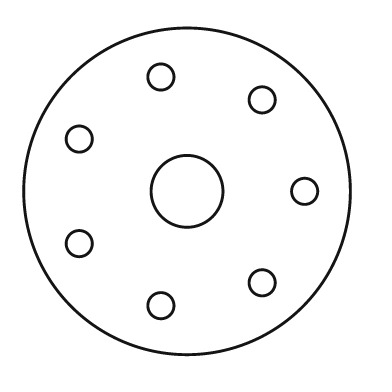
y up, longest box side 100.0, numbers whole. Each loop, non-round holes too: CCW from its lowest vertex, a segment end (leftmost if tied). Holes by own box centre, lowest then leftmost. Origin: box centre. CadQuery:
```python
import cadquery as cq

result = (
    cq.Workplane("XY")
    .moveTo(0.0, 0.0)
    .circle(50.0)
    .moveTo(-8.0, -35.0)
    .circle(4.0)
    .moveTo(23.0, -28.0)
    .circle(4.0)
    .moveTo(-33.0, -16.0)
    .circle(4.0)
    .moveTo(0.0, 0.0)
    .circle(11.0)
    .moveTo(36.0, 0.0)
    .circle(4.0)
    .moveTo(-33.0, 16.0)
    .circle(4.0)
    .moveTo(23.0, 28.0)
    .circle(4.0)
    .moveTo(-8.0, 35.0)
    .circle(4.0)
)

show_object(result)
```